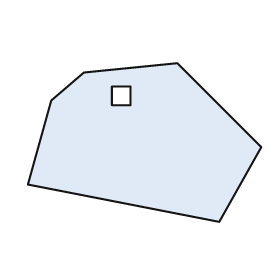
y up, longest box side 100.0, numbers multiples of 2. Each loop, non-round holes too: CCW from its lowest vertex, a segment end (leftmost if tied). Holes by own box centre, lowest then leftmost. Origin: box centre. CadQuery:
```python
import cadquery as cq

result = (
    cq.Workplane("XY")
    .moveTo(32.0, -34.0)
    .lineTo(50.0, -2.0)
    .lineTo(14.0, 34.0)
    .lineTo(-26.0, 30.0)
    .lineTo(-40.0, 18.0)
    .lineTo(-50.0, -18.0)
    .close()
    .moveTo(-14.0, 16.0)
    .lineTo(-6.0, 16.0)
    .lineTo(-6.0, 24.0)
    .lineTo(-14.0, 24.0)
    .close()
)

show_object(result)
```